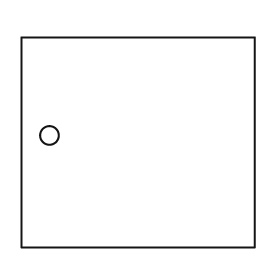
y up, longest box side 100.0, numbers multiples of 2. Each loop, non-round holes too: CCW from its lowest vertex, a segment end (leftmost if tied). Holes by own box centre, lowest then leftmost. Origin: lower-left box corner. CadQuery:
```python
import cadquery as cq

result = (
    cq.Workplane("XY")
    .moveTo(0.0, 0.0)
    .lineTo(100.0, 0.0)
    .lineTo(100.0, 90.0)
    .lineTo(0.0, 90.0)
    .close()
    .moveTo(12.0, 48.0)
    .circle(4.0)
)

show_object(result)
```